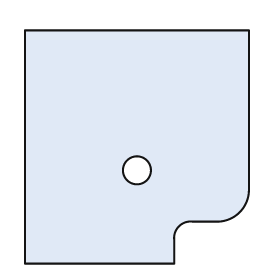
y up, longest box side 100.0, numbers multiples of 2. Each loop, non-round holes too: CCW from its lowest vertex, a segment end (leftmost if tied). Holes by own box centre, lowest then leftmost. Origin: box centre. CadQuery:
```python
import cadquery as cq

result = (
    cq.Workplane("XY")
    .moveTo(-48.0, -50.0)
    .lineTo(16.0, -50.0)
    .lineTo(16.0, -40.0)
    .threePointArc((18.0, -34.0), (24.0, -32.0))
    .lineTo(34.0, -32.0)
    .threePointArc((44.0, -28.0), (48.0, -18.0))
    .lineTo(48.0, 50.0)
    .lineTo(-48.0, 50.0)
    .close()
    .moveTo(0.0, -10.0)
    .circle(6.0)
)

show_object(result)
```